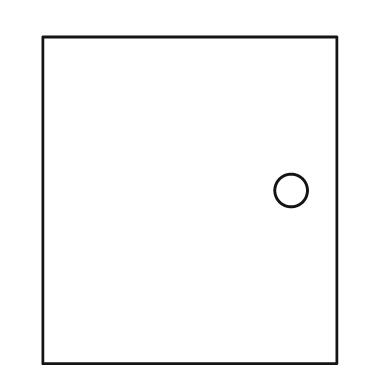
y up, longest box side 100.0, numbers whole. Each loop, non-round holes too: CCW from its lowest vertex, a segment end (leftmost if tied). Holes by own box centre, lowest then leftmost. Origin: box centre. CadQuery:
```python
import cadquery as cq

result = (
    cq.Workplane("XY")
    .moveTo(-45.0, -50.0)
    .lineTo(45.0, -50.0)
    .lineTo(45.0, 50.0)
    .lineTo(-45.0, 50.0)
    .close()
    .moveTo(31.0, 3.0)
    .circle(5.0)
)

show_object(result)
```